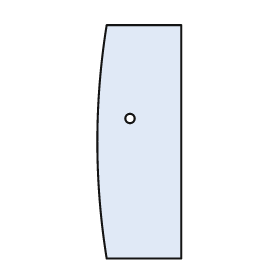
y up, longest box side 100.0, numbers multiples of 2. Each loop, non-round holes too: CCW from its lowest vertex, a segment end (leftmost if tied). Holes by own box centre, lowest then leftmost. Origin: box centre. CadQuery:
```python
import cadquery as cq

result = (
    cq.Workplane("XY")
    .moveTo(-14.0, -50.0)
    .lineTo(18.0, -50.0)
    .lineTo(18.0, 50.0)
    .lineTo(-14.0, 50.0)
    .threePointArc((-18.0, 0.0), (-14.0, -50.0))
    .close()
    .moveTo(-4.0, 10.0)
    .circle(2.0)
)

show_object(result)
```